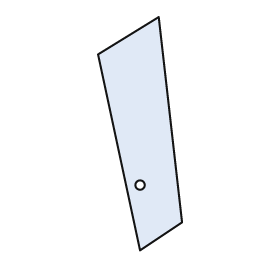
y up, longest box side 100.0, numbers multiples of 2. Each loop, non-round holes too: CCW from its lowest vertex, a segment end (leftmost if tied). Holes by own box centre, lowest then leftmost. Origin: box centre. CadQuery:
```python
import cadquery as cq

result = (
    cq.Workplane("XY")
    .moveTo(0.0, -50.0)
    .lineTo(18.0, -38.0)
    .lineTo(8.0, 50.0)
    .lineTo(-18.0, 34.0)
    .close()
    .moveTo(0.0, -22.0)
    .circle(2.0)
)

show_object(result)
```